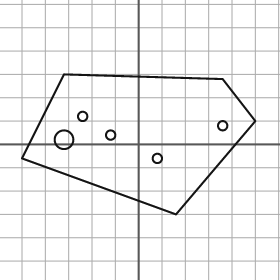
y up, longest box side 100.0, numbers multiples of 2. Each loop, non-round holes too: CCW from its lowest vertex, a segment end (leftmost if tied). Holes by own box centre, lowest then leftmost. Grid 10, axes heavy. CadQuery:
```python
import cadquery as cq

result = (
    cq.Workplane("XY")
    .moveTo(16.0, -30.0)
    .lineTo(50.0, 10.0)
    .lineTo(36.0, 28.0)
    .lineTo(-32.0, 30.0)
    .lineTo(-50.0, -6.0)
    .close()
    .moveTo(8.0, -6.0)
    .circle(2.0)
    .moveTo(-32.0, 2.0)
    .circle(4.0)
    .moveTo(-12.0, 4.0)
    .circle(2.0)
    .moveTo(36.0, 8.0)
    .circle(2.0)
    .moveTo(-24.0, 12.0)
    .circle(2.0)
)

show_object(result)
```